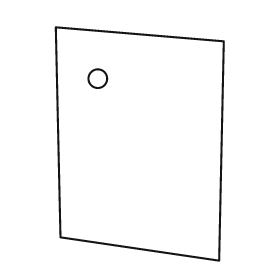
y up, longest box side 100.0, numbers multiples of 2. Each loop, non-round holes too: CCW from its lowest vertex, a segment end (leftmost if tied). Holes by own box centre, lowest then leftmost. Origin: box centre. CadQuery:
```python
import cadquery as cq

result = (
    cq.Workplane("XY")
    .moveTo(34.0, -50.0)
    .lineTo(36.0, 44.0)
    .lineTo(-36.0, 50.0)
    .lineTo(-34.0, -40.0)
    .close()
    .moveTo(-18.0, 28.0)
    .circle(4.0)
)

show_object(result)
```